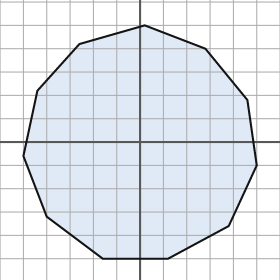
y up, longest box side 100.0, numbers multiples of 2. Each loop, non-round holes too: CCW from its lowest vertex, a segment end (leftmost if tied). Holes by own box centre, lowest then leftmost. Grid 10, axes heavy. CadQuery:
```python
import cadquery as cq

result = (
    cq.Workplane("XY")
    .moveTo(-16.0, -50.0)
    .lineTo(12.0, -50.0)
    .lineTo(38.0, -36.0)
    .lineTo(50.0, -10.0)
    .lineTo(46.0, 18.0)
    .lineTo(28.0, 40.0)
    .lineTo(2.0, 50.0)
    .lineTo(-26.0, 42.0)
    .lineTo(-44.0, 22.0)
    .lineTo(-50.0, -6.0)
    .lineTo(-40.0, -32.0)
    .close()
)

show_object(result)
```